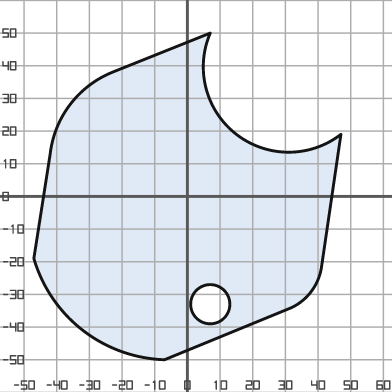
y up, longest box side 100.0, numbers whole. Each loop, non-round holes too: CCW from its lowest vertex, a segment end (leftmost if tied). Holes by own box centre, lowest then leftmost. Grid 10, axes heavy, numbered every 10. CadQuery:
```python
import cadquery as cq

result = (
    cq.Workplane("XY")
    .moveTo(-7.0, -50.0)
    .lineTo(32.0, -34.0)
    .threePointArc((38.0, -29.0), (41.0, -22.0))
    .lineTo(47.0, 19.0)
    .threePointArc((15.0, 19.0), (7.0, 50.0))
    .lineTo(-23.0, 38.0)
    .threePointArc((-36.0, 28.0), (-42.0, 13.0))
    .lineTo(-47.0, -19.0)
    .threePointArc((-32.0, -41.0), (-7.0, -50.0))
    .close()
    .moveTo(7.0, -33.0)
    .circle(6.0)
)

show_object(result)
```